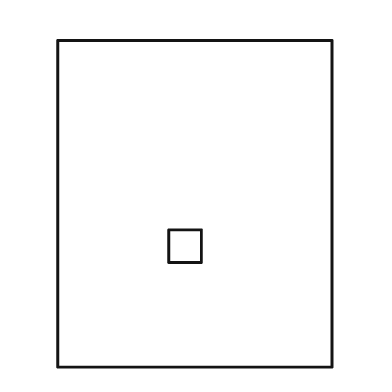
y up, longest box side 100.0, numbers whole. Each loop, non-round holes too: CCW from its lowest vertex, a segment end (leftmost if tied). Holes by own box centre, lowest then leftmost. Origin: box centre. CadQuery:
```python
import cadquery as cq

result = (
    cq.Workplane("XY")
    .moveTo(-42.0, -50.0)
    .lineTo(42.0, -50.0)
    .lineTo(42.0, 50.0)
    .lineTo(-42.0, 50.0)
    .close()
    .moveTo(-8.0, -18.0)
    .lineTo(2.0, -18.0)
    .lineTo(2.0, -8.0)
    .lineTo(-8.0, -8.0)
    .close()
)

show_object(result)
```